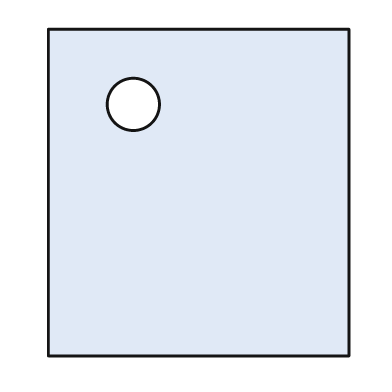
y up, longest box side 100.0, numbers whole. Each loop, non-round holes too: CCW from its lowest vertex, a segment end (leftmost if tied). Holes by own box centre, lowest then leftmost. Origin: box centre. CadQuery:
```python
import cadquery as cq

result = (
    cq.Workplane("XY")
    .moveTo(-46.0, -50.0)
    .lineTo(46.0, -50.0)
    .lineTo(46.0, 50.0)
    .lineTo(-46.0, 50.0)
    .close()
    .moveTo(-20.0, 27.0)
    .circle(8.0)
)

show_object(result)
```